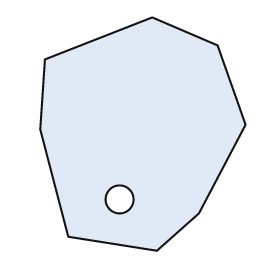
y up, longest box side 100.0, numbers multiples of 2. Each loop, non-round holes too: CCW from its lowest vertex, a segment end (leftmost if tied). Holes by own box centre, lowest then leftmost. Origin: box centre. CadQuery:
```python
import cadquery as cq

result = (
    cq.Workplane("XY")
    .moveTo(6.0, -50.0)
    .lineTo(24.0, -34.0)
    .lineTo(44.0, 4.0)
    .lineTo(32.0, 38.0)
    .lineTo(4.0, 50.0)
    .lineTo(-42.0, 32.0)
    .lineTo(-44.0, 2.0)
    .lineTo(-32.0, -44.0)
    .close()
    .moveTo(-10.0, -28.0)
    .circle(6.0)
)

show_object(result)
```